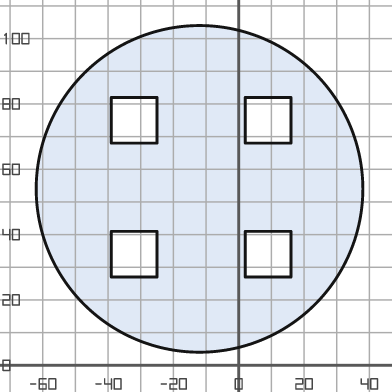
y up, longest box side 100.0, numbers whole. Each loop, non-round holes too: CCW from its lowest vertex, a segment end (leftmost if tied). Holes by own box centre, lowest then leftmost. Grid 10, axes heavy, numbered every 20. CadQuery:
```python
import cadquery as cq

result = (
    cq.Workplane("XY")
    .moveTo(-12.0, 54.0)
    .circle(50.0)
    .moveTo(-39.0, 27.0)
    .lineTo(-25.0, 27.0)
    .lineTo(-25.0, 41.0)
    .lineTo(-39.0, 41.0)
    .close()
    .moveTo(2.0, 27.0)
    .lineTo(16.0, 27.0)
    .lineTo(16.0, 41.0)
    .lineTo(2.0, 41.0)
    .close()
    .moveTo(-39.0, 68.0)
    .lineTo(-25.0, 68.0)
    .lineTo(-25.0, 82.0)
    .lineTo(-39.0, 82.0)
    .close()
    .moveTo(2.0, 68.0)
    .lineTo(16.0, 68.0)
    .lineTo(16.0, 82.0)
    .lineTo(2.0, 82.0)
    .close()
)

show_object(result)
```